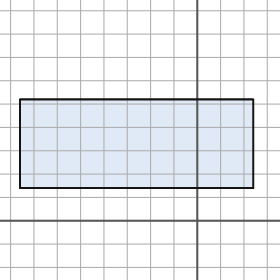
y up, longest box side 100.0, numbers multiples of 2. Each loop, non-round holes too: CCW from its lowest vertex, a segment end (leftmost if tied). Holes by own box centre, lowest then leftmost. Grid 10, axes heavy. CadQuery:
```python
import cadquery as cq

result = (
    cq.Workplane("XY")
    .moveTo(-76.0, 14.0)
    .lineTo(24.0, 14.0)
    .lineTo(24.0, 52.0)
    .lineTo(-76.0, 52.0)
    .close()
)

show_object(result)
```